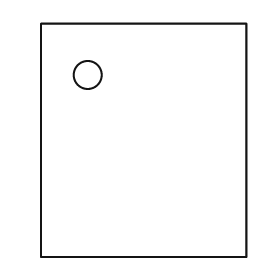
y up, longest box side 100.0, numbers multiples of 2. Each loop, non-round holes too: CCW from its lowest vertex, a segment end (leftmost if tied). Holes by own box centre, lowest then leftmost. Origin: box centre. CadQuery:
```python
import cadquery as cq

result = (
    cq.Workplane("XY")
    .moveTo(-44.0, -50.0)
    .lineTo(44.0, -50.0)
    .lineTo(44.0, 50.0)
    .lineTo(-44.0, 50.0)
    .close()
    .moveTo(-24.0, 28.0)
    .circle(6.0)
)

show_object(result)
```